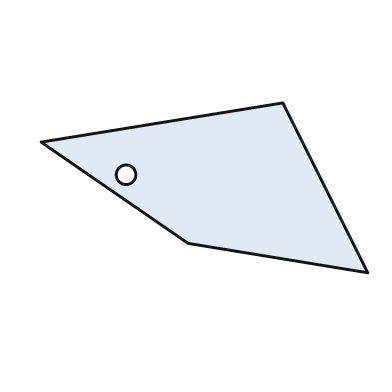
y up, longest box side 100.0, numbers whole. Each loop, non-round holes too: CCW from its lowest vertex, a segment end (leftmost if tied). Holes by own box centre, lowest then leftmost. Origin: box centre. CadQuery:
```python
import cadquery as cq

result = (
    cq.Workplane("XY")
    .moveTo(50.0, -26.0)
    .lineTo(24.0, 26.0)
    .lineTo(-50.0, 14.0)
    .lineTo(-5.0, -17.0)
    .close()
    .moveTo(-24.0, 4.0)
    .circle(3.0)
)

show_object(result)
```